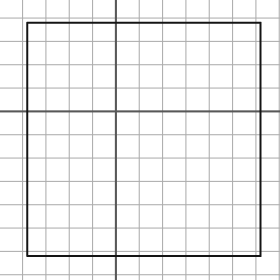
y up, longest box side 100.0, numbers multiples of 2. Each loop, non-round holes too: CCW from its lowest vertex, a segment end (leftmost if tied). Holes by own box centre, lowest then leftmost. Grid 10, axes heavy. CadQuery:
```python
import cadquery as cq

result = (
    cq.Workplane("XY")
    .moveTo(-38.0, -62.0)
    .lineTo(62.0, -62.0)
    .lineTo(62.0, 38.0)
    .lineTo(-38.0, 38.0)
    .close()
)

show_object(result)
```